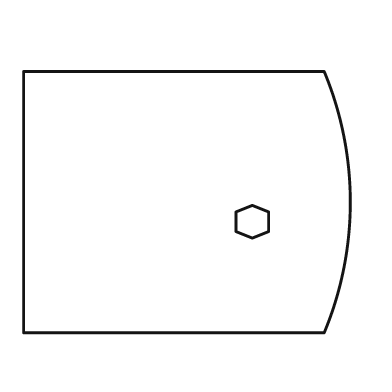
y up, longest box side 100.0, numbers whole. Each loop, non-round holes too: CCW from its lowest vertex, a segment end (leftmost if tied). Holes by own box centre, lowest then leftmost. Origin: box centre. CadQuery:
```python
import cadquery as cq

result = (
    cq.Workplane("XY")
    .moveTo(-50.0, -40.0)
    .lineTo(42.0, -40.0)
    .threePointArc((50.0, 0.0), (42.0, 40.0))
    .lineTo(-50.0, 40.0)
    .close()
    .moveTo(20.0, -11.0)
    .lineTo(25.0, -9.0)
    .lineTo(25.0, -3.0)
    .lineTo(20.0, -1.0)
    .lineTo(15.0, -3.0)
    .lineTo(15.0, -9.0)
    .close()
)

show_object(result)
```